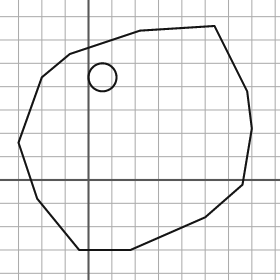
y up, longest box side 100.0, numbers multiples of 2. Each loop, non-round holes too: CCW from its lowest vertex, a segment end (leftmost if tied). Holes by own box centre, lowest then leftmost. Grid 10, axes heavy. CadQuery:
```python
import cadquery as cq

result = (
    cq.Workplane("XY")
    .moveTo(-4.0, -30.0)
    .lineTo(18.0, -30.0)
    .lineTo(50.0, -16.0)
    .lineTo(66.0, -2.0)
    .lineTo(70.0, 22.0)
    .lineTo(68.0, 38.0)
    .lineTo(54.0, 66.0)
    .lineTo(22.0, 64.0)
    .lineTo(-8.0, 54.0)
    .lineTo(-20.0, 44.0)
    .lineTo(-30.0, 16.0)
    .lineTo(-22.0, -8.0)
    .close()
    .moveTo(6.0, 44.0)
    .circle(6.0)
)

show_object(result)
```